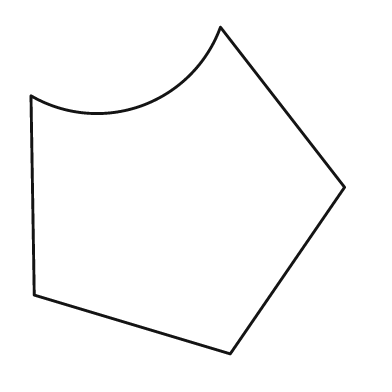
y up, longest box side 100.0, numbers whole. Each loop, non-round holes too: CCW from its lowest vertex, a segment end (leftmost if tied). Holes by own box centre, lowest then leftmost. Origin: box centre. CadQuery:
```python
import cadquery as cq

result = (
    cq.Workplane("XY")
    .moveTo(13.0, -50.0)
    .lineTo(48.0, 1.0)
    .lineTo(10.0, 50.0)
    .threePointArc((-14.0, 26.0), (-48.0, 29.0))
    .lineTo(-47.0, -32.0)
    .close()
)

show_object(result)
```